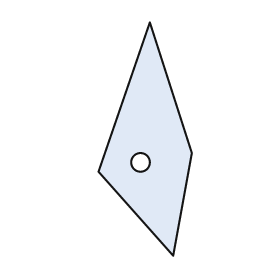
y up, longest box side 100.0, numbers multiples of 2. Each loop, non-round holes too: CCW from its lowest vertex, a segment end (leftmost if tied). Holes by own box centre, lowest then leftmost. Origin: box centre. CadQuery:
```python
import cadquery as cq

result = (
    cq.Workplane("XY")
    .moveTo(12.0, -50.0)
    .lineTo(20.0, -6.0)
    .lineTo(2.0, 50.0)
    .lineTo(-20.0, -14.0)
    .close()
    .moveTo(-2.0, -10.0)
    .circle(4.0)
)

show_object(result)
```